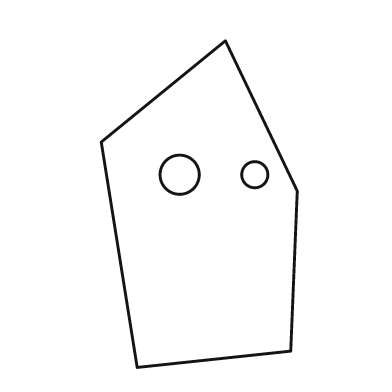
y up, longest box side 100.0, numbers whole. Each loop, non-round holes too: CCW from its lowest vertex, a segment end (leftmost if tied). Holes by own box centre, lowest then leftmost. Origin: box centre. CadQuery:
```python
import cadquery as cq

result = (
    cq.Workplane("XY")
    .moveTo(-19.0, -50.0)
    .lineTo(28.0, -45.0)
    .lineTo(30.0, 4.0)
    .lineTo(8.0, 50.0)
    .lineTo(-30.0, 19.0)
    .close()
    .moveTo(-6.0, 9.0)
    .circle(6.0)
    .moveTo(17.0, 9.0)
    .circle(4.0)
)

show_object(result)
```